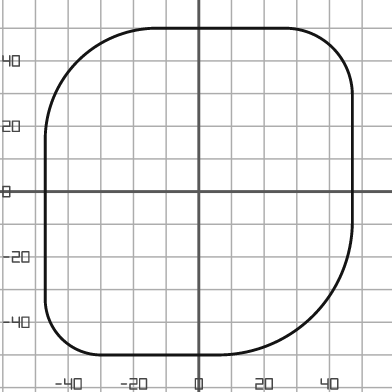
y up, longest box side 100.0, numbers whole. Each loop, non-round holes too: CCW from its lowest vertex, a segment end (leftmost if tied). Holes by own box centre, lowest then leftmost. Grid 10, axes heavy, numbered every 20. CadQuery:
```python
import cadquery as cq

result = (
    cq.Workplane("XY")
    .moveTo(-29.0, -50.0)
    .lineTo(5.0, -50.0)
    .threePointArc((35.0, -38.0), (47.0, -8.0))
    .lineTo(47.0, 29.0)
    .threePointArc((41.0, 44.0), (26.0, 50.0))
    .lineTo(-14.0, 50.0)
    .threePointArc((-37.0, 40.0), (-47.0, 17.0))
    .lineTo(-47.0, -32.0)
    .threePointArc((-42.0, -45.0), (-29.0, -50.0))
    .close()
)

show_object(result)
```